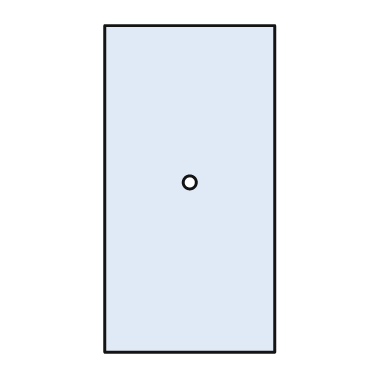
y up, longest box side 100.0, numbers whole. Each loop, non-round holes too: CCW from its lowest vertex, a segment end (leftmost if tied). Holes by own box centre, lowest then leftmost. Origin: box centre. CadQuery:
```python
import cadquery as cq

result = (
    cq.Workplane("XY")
    .moveTo(-26.0, -50.0)
    .lineTo(26.0, -50.0)
    .lineTo(26.0, 50.0)
    .lineTo(-26.0, 50.0)
    .close()
    .moveTo(0.0, 2.0)
    .circle(2.0)
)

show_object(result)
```